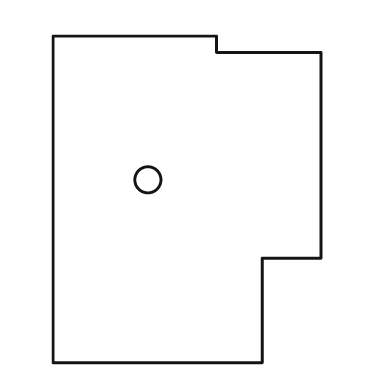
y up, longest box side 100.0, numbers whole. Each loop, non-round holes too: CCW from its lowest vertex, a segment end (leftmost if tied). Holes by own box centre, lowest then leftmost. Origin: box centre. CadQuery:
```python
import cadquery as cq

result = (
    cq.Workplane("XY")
    .moveTo(-41.0, -50.0)
    .lineTo(23.0, -50.0)
    .lineTo(23.0, -18.0)
    .lineTo(41.0, -18.0)
    .lineTo(41.0, 45.0)
    .lineTo(9.0, 45.0)
    .lineTo(9.0, 50.0)
    .lineTo(-41.0, 50.0)
    .close()
    .moveTo(-12.0, 6.0)
    .circle(4.0)
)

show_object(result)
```